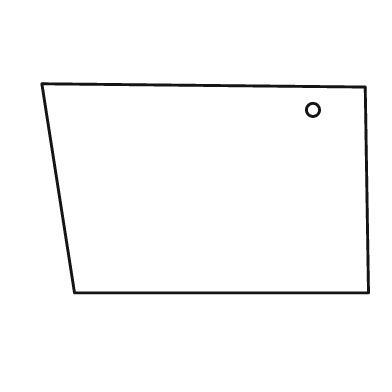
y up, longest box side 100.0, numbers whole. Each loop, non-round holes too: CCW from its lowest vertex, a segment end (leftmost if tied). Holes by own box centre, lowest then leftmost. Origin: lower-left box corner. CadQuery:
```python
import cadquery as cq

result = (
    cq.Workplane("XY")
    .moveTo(10.0, 0.0)
    .lineTo(100.0, 0.0)
    .lineTo(99.0, 63.0)
    .lineTo(0.0, 64.0)
    .close()
    .moveTo(83.0, 56.0)
    .circle(2.0)
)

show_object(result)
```